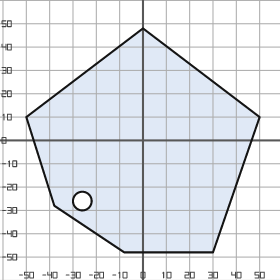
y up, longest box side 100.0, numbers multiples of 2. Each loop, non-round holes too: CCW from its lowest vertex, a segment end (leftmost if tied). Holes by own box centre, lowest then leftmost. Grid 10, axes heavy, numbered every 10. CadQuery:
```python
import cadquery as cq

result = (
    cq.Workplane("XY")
    .moveTo(-8.0, -48.0)
    .lineTo(30.0, -48.0)
    .lineTo(50.0, 10.0)
    .lineTo(0.0, 48.0)
    .lineTo(-50.0, 10.0)
    .lineTo(-38.0, -28.0)
    .close()
    .moveTo(-26.0, -26.0)
    .circle(4.0)
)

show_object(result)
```